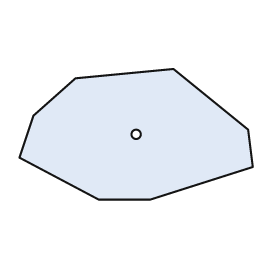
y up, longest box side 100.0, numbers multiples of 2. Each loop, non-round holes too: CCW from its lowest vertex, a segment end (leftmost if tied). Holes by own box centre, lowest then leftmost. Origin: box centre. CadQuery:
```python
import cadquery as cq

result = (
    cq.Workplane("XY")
    .moveTo(-16.0, -28.0)
    .lineTo(6.0, -28.0)
    .lineTo(50.0, -14.0)
    .lineTo(48.0, 2.0)
    .lineTo(16.0, 28.0)
    .lineTo(-26.0, 24.0)
    .lineTo(-44.0, 8.0)
    .lineTo(-50.0, -10.0)
    .close()
    .moveTo(0.0, 0.0)
    .circle(2.0)
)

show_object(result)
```